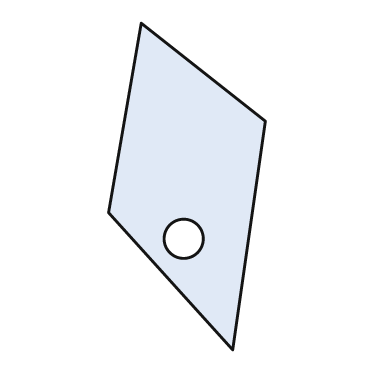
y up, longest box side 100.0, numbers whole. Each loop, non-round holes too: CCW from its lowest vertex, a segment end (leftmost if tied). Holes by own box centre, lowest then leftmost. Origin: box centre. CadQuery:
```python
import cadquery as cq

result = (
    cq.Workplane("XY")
    .moveTo(14.0, -50.0)
    .lineTo(24.0, 20.0)
    .lineTo(-14.0, 50.0)
    .lineTo(-24.0, -8.0)
    .close()
    .moveTo(-1.0, -16.0)
    .circle(6.0)
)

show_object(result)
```